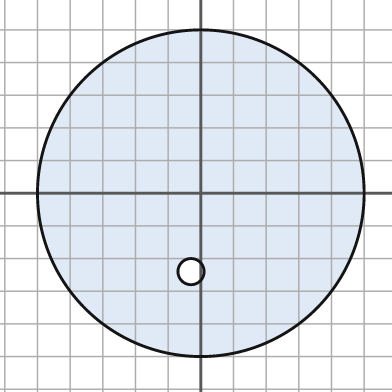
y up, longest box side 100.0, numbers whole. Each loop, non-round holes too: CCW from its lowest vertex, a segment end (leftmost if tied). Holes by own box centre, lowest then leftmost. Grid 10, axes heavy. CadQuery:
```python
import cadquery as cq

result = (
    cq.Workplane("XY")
    .moveTo(0.0, 0.0)
    .circle(50.0)
    .moveTo(-3.0, -24.0)
    .circle(4.0)
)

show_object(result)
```